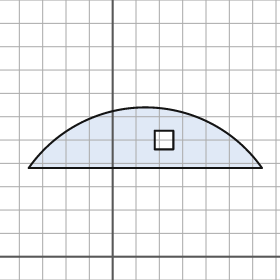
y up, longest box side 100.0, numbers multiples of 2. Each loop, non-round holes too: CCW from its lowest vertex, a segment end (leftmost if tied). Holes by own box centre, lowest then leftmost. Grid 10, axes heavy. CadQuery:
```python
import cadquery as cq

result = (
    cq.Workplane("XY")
    .moveTo(-36.0, 38.0)
    .lineTo(64.0, 38.0)
    .threePointArc((14.0, 64.0), (-36.0, 38.0))
    .close()
    .moveTo(18.0, 46.0)
    .lineTo(26.0, 46.0)
    .lineTo(26.0, 54.0)
    .lineTo(18.0, 54.0)
    .close()
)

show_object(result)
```